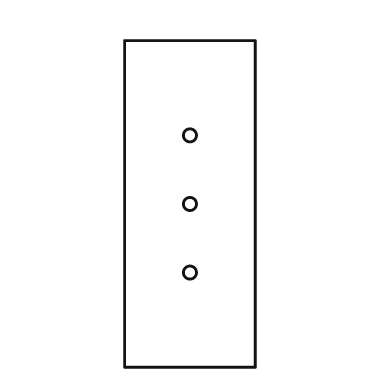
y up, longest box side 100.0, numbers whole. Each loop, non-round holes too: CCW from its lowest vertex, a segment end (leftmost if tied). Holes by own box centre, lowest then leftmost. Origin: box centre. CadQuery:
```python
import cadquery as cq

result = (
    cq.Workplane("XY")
    .moveTo(-20.0, -50.0)
    .lineTo(20.0, -50.0)
    .lineTo(20.0, 50.0)
    .lineTo(-20.0, 50.0)
    .close()
    .moveTo(0.0, -21.0)
    .circle(2.0)
    .moveTo(0.0, 0.0)
    .circle(2.0)
    .moveTo(0.0, 21.0)
    .circle(2.0)
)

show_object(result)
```